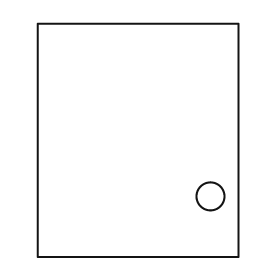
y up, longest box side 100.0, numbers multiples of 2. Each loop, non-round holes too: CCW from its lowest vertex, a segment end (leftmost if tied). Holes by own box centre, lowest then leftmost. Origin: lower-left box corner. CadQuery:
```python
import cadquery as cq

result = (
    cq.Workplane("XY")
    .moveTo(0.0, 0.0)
    .lineTo(86.0, 0.0)
    .lineTo(86.0, 100.0)
    .lineTo(0.0, 100.0)
    .close()
    .moveTo(74.0, 26.0)
    .circle(6.0)
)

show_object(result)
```